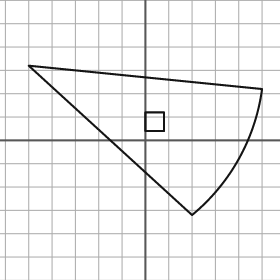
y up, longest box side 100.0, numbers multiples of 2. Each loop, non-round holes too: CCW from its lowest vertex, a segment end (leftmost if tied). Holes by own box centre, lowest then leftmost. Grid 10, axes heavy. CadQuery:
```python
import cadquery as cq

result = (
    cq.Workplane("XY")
    .moveTo(20.0, -32.0)
    .threePointArc((40.0, -8.0), (50.0, 22.0))
    .lineTo(-50.0, 32.0)
    .close()
    .moveTo(0.0, 4.0)
    .lineTo(8.0, 4.0)
    .lineTo(8.0, 12.0)
    .lineTo(0.0, 12.0)
    .close()
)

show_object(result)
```